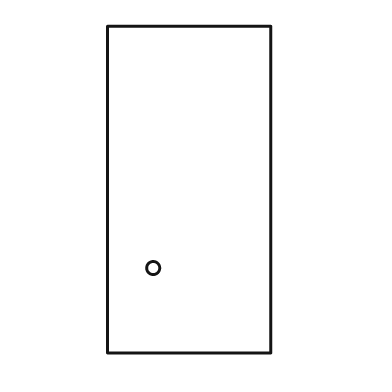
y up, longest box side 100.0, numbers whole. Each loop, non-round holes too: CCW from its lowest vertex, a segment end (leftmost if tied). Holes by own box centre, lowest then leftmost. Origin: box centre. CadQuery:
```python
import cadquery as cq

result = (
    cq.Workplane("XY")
    .moveTo(-25.0, -50.0)
    .lineTo(25.0, -50.0)
    .lineTo(25.0, 50.0)
    .lineTo(-25.0, 50.0)
    .close()
    .moveTo(-11.0, -24.0)
    .circle(2.0)
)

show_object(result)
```